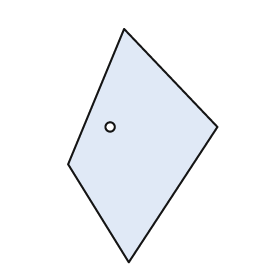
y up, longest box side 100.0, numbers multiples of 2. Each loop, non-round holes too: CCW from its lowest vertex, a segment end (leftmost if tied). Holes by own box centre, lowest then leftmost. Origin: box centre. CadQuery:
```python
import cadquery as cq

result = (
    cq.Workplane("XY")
    .moveTo(-6.0, -50.0)
    .lineTo(32.0, 8.0)
    .lineTo(-8.0, 50.0)
    .lineTo(-32.0, -8.0)
    .close()
    .moveTo(-14.0, 8.0)
    .circle(2.0)
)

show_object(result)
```